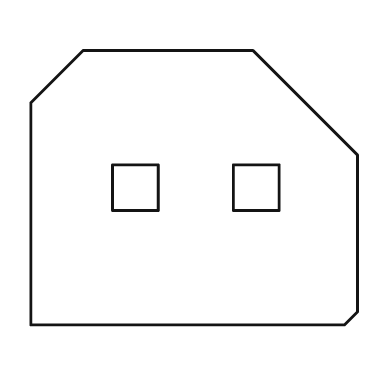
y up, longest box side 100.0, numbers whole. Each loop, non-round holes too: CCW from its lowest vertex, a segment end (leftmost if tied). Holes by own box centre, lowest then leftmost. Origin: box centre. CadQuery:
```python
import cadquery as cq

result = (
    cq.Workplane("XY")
    .moveTo(-50.0, -42.0)
    .lineTo(46.0, -42.0)
    .lineTo(50.0, -38.0)
    .lineTo(50.0, 10.0)
    .lineTo(18.0, 42.0)
    .lineTo(-34.0, 42.0)
    .lineTo(-50.0, 26.0)
    .close()
    .moveTo(-25.0, -7.0)
    .lineTo(-11.0, -7.0)
    .lineTo(-11.0, 7.0)
    .lineTo(-25.0, 7.0)
    .close()
    .moveTo(12.0, -7.0)
    .lineTo(26.0, -7.0)
    .lineTo(26.0, 7.0)
    .lineTo(12.0, 7.0)
    .close()
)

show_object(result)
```